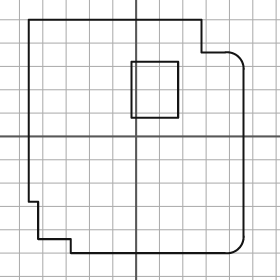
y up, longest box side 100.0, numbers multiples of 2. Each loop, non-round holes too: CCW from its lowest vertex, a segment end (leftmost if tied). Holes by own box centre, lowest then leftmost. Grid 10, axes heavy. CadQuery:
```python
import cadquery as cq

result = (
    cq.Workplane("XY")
    .moveTo(-28.0, -50.0)
    .lineTo(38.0, -50.0)
    .threePointArc((44.0, -48.0), (46.0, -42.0))
    .lineTo(46.0, 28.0)
    .threePointArc((44.0, 34.0), (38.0, 36.0))
    .lineTo(28.0, 36.0)
    .lineTo(28.0, 50.0)
    .lineTo(-46.0, 50.0)
    .lineTo(-46.0, -28.0)
    .lineTo(-42.0, -28.0)
    .lineTo(-42.0, -44.0)
    .lineTo(-28.0, -44.0)
    .close()
    .moveTo(-2.0, 8.0)
    .lineTo(18.0, 8.0)
    .lineTo(18.0, 32.0)
    .lineTo(-2.0, 32.0)
    .close()
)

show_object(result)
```